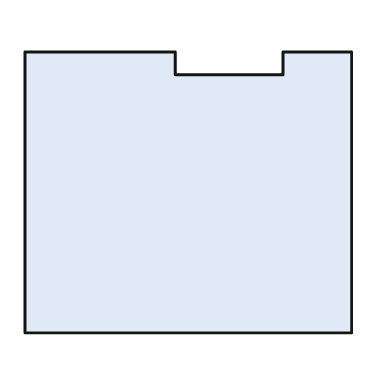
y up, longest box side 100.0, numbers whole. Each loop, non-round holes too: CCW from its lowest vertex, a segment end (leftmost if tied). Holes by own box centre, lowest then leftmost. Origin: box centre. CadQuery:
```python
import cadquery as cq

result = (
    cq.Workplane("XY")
    .moveTo(-50.0, -43.0)
    .lineTo(50.0, -43.0)
    .lineTo(50.0, 43.0)
    .lineTo(29.0, 43.0)
    .lineTo(29.0, 36.0)
    .lineTo(-4.0, 36.0)
    .lineTo(-4.0, 43.0)
    .lineTo(-50.0, 43.0)
    .close()
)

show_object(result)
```